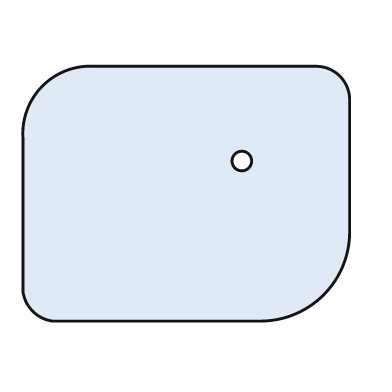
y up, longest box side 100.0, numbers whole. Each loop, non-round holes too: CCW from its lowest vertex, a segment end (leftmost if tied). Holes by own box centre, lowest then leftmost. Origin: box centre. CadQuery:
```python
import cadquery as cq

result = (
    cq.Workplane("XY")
    .moveTo(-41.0, -39.0)
    .lineTo(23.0, -39.0)
    .threePointArc((42.0, -31.0), (50.0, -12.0))
    .lineTo(50.0, 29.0)
    .threePointArc((47.0, 36.0), (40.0, 39.0))
    .lineTo(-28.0, 39.0)
    .threePointArc((-44.0, 33.0), (-50.0, 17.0))
    .lineTo(-50.0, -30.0)
    .threePointArc((-47.0, -36.0), (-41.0, -39.0))
    .close()
    .moveTo(17.0, 10.0)
    .circle(3.0)
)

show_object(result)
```